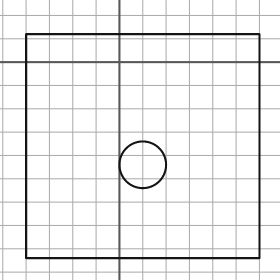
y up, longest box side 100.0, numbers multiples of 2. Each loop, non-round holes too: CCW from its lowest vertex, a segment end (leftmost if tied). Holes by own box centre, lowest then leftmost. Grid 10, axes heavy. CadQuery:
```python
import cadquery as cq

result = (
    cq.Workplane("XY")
    .moveTo(-40.0, -84.0)
    .lineTo(60.0, -84.0)
    .lineTo(60.0, 12.0)
    .lineTo(-40.0, 12.0)
    .close()
    .moveTo(10.0, -44.0)
    .circle(10.0)
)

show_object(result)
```